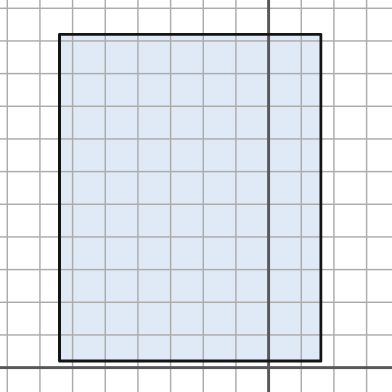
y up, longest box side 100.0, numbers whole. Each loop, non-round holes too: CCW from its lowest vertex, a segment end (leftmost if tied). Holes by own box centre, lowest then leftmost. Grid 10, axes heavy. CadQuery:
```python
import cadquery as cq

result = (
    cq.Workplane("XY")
    .moveTo(-64.0, 2.0)
    .lineTo(16.0, 2.0)
    .lineTo(16.0, 102.0)
    .lineTo(-64.0, 102.0)
    .close()
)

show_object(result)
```